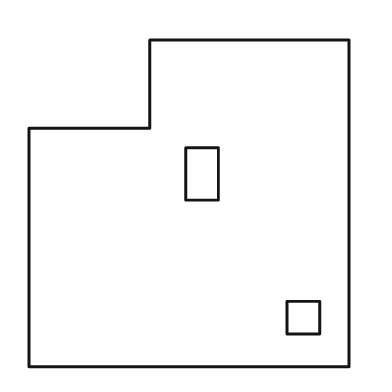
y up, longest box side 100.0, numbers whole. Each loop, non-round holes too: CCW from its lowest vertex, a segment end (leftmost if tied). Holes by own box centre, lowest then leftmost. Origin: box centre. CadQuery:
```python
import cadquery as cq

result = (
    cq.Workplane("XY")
    .moveTo(-49.0, -50.0)
    .lineTo(49.0, -50.0)
    .lineTo(49.0, 50.0)
    .lineTo(-12.0, 50.0)
    .lineTo(-12.0, 23.0)
    .lineTo(-49.0, 23.0)
    .close()
    .moveTo(30.0, -40.0)
    .lineTo(40.0, -40.0)
    .lineTo(40.0, -30.0)
    .lineTo(30.0, -30.0)
    .close()
    .moveTo(-1.0, 1.0)
    .lineTo(9.0, 1.0)
    .lineTo(9.0, 17.0)
    .lineTo(-1.0, 17.0)
    .close()
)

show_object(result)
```